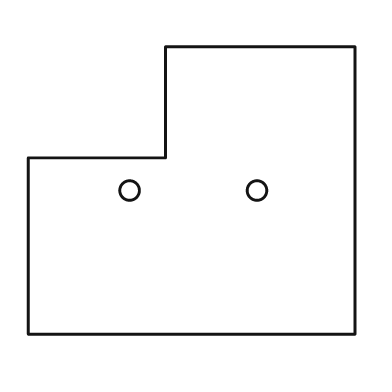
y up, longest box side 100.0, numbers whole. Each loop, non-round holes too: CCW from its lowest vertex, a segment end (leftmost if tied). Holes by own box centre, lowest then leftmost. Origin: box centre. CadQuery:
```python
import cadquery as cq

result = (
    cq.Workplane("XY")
    .moveTo(-50.0, -44.0)
    .lineTo(50.0, -44.0)
    .lineTo(50.0, 44.0)
    .lineTo(-8.0, 44.0)
    .lineTo(-8.0, 10.0)
    .lineTo(-50.0, 10.0)
    .close()
    .moveTo(-19.0, 0.0)
    .circle(3.0)
    .moveTo(20.0, 0.0)
    .circle(3.0)
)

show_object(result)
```